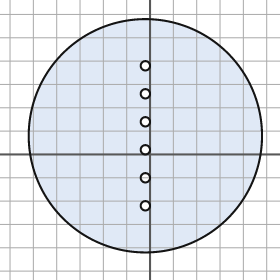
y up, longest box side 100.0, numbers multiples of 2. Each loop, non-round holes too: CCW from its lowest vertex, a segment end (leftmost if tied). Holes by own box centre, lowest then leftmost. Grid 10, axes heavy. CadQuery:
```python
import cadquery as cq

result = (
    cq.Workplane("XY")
    .moveTo(-2.0, 8.0)
    .circle(50.0)
    .moveTo(-2.0, -22.0)
    .circle(2.0)
    .moveTo(-2.0, -10.0)
    .circle(2.0)
    .moveTo(-2.0, 2.0)
    .circle(2.0)
    .moveTo(-2.0, 14.0)
    .circle(2.0)
    .moveTo(-2.0, 26.0)
    .circle(2.0)
    .moveTo(-2.0, 38.0)
    .circle(2.0)
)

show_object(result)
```